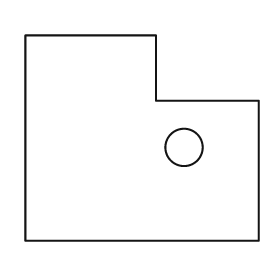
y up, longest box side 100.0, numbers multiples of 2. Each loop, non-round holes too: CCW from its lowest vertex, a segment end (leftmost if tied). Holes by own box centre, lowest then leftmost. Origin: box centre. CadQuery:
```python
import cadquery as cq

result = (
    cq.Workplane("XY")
    .moveTo(-50.0, -44.0)
    .lineTo(50.0, -44.0)
    .lineTo(50.0, 16.0)
    .lineTo(6.0, 16.0)
    .lineTo(6.0, 44.0)
    .lineTo(-50.0, 44.0)
    .close()
    .moveTo(18.0, -4.0)
    .circle(8.0)
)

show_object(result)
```